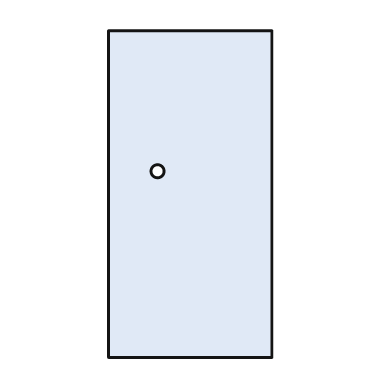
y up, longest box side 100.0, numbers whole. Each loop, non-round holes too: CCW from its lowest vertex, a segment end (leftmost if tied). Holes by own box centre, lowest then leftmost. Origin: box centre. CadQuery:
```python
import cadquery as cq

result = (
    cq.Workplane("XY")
    .moveTo(-25.0, -50.0)
    .lineTo(25.0, -50.0)
    .lineTo(25.0, 50.0)
    .lineTo(-25.0, 50.0)
    .close()
    .moveTo(-10.0, 7.0)
    .circle(2.0)
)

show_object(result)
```